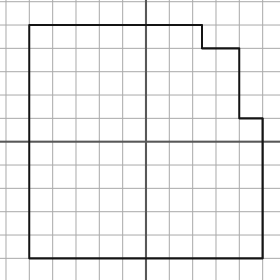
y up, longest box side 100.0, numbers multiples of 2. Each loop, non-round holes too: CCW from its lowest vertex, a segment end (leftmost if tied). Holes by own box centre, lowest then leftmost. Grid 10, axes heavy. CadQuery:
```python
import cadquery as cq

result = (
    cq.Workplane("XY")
    .moveTo(-50.0, -50.0)
    .lineTo(50.0, -50.0)
    .lineTo(50.0, 10.0)
    .lineTo(40.0, 10.0)
    .lineTo(40.0, 40.0)
    .lineTo(24.0, 40.0)
    .lineTo(24.0, 50.0)
    .lineTo(-50.0, 50.0)
    .close()
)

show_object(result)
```